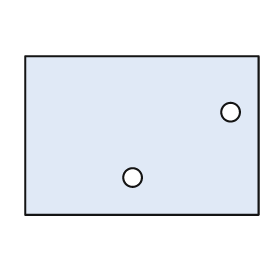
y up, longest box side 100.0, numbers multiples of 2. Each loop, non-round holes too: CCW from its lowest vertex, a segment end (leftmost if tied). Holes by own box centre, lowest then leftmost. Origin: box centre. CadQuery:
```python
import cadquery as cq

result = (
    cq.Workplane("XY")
    .moveTo(-50.0, -34.0)
    .lineTo(50.0, -34.0)
    .lineTo(50.0, 34.0)
    .lineTo(-50.0, 34.0)
    .close()
    .moveTo(-4.0, -18.0)
    .circle(4.0)
    .moveTo(38.0, 10.0)
    .circle(4.0)
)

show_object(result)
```